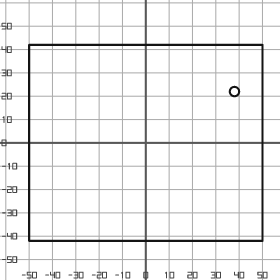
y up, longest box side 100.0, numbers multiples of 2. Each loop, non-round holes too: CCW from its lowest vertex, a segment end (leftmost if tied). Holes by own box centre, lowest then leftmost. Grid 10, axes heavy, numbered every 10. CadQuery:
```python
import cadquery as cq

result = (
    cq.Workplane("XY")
    .moveTo(-50.0, -42.0)
    .lineTo(50.0, -42.0)
    .lineTo(50.0, 42.0)
    .lineTo(-50.0, 42.0)
    .close()
    .moveTo(38.0, 22.0)
    .circle(2.0)
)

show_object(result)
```